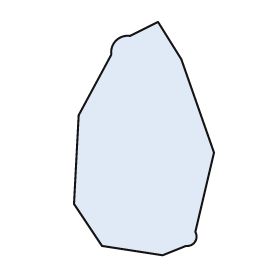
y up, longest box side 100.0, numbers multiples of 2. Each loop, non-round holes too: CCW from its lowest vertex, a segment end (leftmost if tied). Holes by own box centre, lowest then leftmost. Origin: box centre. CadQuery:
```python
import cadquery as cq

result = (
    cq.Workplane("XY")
    .moveTo(8.0, -50.0)
    .lineTo(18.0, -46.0)
    .threePointArc((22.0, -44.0), (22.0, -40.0))
    .lineTo(30.0, -6.0)
    .lineTo(16.0, 34.0)
    .lineTo(6.0, 50.0)
    .lineTo(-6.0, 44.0)
    .threePointArc((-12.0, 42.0), (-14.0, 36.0))
    .lineTo(-28.0, 10.0)
    .lineTo(-30.0, -28.0)
    .lineTo(-18.0, -46.0)
    .close()
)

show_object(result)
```